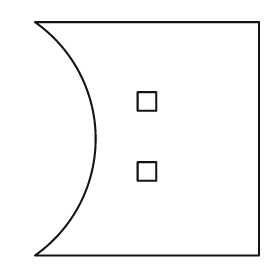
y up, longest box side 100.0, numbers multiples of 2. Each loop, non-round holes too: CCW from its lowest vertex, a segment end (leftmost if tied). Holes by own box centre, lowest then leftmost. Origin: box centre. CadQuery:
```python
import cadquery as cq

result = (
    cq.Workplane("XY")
    .moveTo(-48.0, -50.0)
    .lineTo(48.0, -50.0)
    .lineTo(48.0, 50.0)
    .lineTo(-48.0, 50.0)
    .threePointArc((-22.0, 0.0), (-48.0, -50.0))
    .close()
    .moveTo(-4.0, -18.0)
    .lineTo(4.0, -18.0)
    .lineTo(4.0, -10.0)
    .lineTo(-4.0, -10.0)
    .close()
    .moveTo(-4.0, 12.0)
    .lineTo(4.0, 12.0)
    .lineTo(4.0, 20.0)
    .lineTo(-4.0, 20.0)
    .close()
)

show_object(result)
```